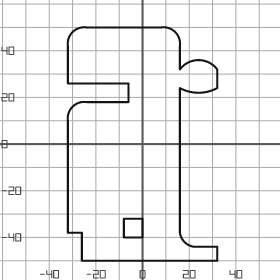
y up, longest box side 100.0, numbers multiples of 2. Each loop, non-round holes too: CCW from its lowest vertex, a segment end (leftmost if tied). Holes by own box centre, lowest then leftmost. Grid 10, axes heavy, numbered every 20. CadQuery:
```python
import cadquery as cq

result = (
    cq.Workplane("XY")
    .moveTo(-26.0, -50.0)
    .lineTo(32.0, -50.0)
    .lineTo(32.0, -44.0)
    .lineTo(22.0, -44.0)
    .threePointArc((18.0, -42.0), (16.0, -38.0))
    .lineTo(16.0, 24.0)
    .threePointArc((24.0, 22.0), (32.0, 24.0))
    .lineTo(32.0, 32.0)
    .threePointArc((24.0, 36.0), (16.0, 32.0))
    .lineTo(16.0, 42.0)
    .threePointArc((14.0, 48.0), (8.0, 50.0))
    .lineTo(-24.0, 50.0)
    .threePointArc((-30.0, 48.0), (-32.0, 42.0))
    .lineTo(-32.0, 26.0)
    .lineTo(-6.0, 26.0)
    .lineTo(-6.0, 18.0)
    .lineTo(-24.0, 18.0)
    .threePointArc((-30.0, 16.0), (-32.0, 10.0))
    .lineTo(-32.0, -38.0)
    .lineTo(-26.0, -38.0)
    .close()
    .moveTo(-8.0, -40.0)
    .lineTo(0.0, -40.0)
    .lineTo(0.0, -32.0)
    .lineTo(-8.0, -32.0)
    .close()
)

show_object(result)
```